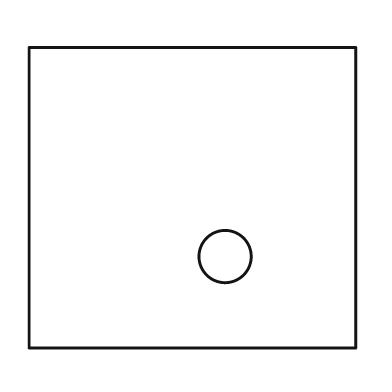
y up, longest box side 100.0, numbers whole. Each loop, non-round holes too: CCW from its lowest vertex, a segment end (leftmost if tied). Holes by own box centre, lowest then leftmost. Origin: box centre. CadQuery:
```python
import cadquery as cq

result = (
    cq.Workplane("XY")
    .moveTo(-50.0, -46.0)
    .lineTo(50.0, -46.0)
    .lineTo(50.0, 46.0)
    .lineTo(-50.0, 46.0)
    .close()
    .moveTo(10.0, -18.0)
    .circle(8.0)
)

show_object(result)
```